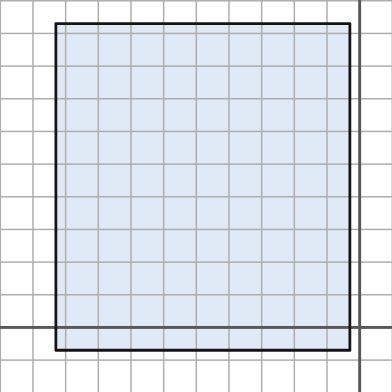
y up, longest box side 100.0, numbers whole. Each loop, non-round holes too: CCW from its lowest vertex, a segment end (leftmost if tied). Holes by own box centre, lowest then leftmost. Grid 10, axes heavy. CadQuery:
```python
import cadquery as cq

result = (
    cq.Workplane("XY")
    .moveTo(-93.0, -7.0)
    .lineTo(-3.0, -7.0)
    .lineTo(-3.0, 93.0)
    .lineTo(-93.0, 93.0)
    .close()
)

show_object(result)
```